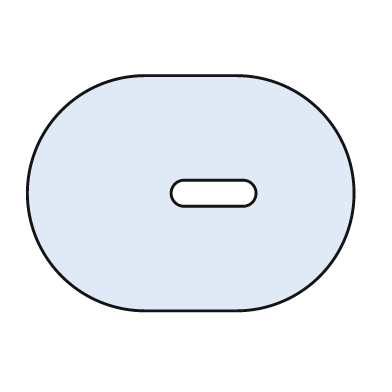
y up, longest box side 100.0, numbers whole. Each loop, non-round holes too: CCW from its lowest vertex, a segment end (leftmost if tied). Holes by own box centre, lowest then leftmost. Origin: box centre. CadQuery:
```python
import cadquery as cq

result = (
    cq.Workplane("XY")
    .moveTo(-14.0, -36.0)
    .lineTo(14.0, -36.0)
    .threePointArc((50.0, 0.0), (14.0, 36.0))
    .lineTo(-14.0, 36.0)
    .threePointArc((-50.0, 0.0), (-14.0, -36.0))
    .close()
    .moveTo(-2.0, -4.0)
    .lineTo(16.0, -4.0)
    .threePointArc((20.0, 0.0), (16.0, 4.0))
    .lineTo(-2.0, 4.0)
    .threePointArc((-6.0, 0.0), (-2.0, -4.0))
    .close()
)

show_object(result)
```